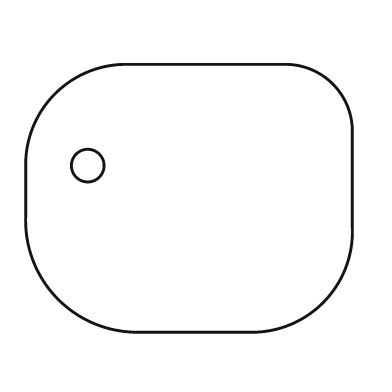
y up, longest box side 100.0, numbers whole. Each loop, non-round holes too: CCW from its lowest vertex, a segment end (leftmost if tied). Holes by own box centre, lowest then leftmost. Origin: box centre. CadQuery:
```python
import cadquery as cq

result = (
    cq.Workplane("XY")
    .moveTo(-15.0, -41.0)
    .lineTo(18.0, -41.0)
    .threePointArc((41.0, -32.0), (50.0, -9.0))
    .lineTo(50.0, 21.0)
    .threePointArc((44.0, 35.0), (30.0, 41.0))
    .lineTo(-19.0, 41.0)
    .threePointArc((-41.0, 32.0), (-50.0, 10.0))
    .lineTo(-50.0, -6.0)
    .threePointArc((-40.0, -31.0), (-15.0, -41.0))
    .close()
    .moveTo(-31.0, 10.0)
    .circle(5.0)
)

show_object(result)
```